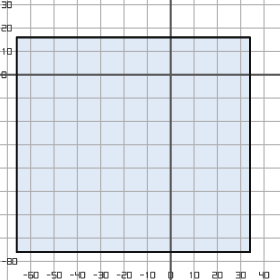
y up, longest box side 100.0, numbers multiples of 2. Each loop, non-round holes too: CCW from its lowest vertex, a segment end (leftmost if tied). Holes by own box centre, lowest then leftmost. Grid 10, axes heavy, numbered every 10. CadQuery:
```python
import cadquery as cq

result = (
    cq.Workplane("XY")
    .moveTo(-66.0, -76.0)
    .lineTo(34.0, -76.0)
    .lineTo(34.0, 16.0)
    .lineTo(-66.0, 16.0)
    .close()
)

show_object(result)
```